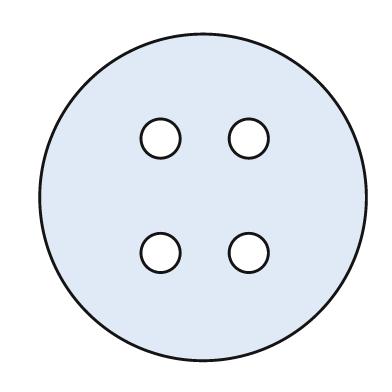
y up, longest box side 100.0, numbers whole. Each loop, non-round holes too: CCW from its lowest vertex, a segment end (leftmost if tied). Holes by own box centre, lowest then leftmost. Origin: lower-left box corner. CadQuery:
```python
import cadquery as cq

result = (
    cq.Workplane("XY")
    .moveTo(50.0, 50.0)
    .circle(50.0)
    .moveTo(37.0, 33.0)
    .circle(6.0)
    .moveTo(64.0, 33.0)
    .circle(6.0)
    .moveTo(37.0, 68.0)
    .circle(6.0)
    .moveTo(64.0, 68.0)
    .circle(6.0)
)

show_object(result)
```